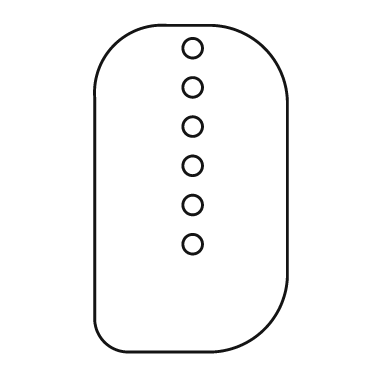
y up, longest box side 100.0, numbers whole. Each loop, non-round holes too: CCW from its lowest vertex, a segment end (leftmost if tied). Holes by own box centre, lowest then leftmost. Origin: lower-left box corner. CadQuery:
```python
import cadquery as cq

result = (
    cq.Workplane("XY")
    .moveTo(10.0, 0.0)
    .lineTo(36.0, 0.0)
    .threePointArc((52.0, 7.0), (59.0, 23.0))
    .lineTo(59.0, 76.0)
    .threePointArc((52.0, 93.0), (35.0, 100.0))
    .lineTo(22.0, 100.0)
    .threePointArc((6.0, 94.0), (0.0, 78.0))
    .lineTo(0.0, 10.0)
    .threePointArc((3.0, 3.0), (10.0, 0.0))
    .close()
    .moveTo(30.0, 33.0)
    .circle(3.0)
    .moveTo(30.0, 45.0)
    .circle(3.0)
    .moveTo(30.0, 57.0)
    .circle(3.0)
    .moveTo(30.0, 69.0)
    .circle(3.0)
    .moveTo(30.0, 81.0)
    .circle(3.0)
    .moveTo(30.0, 93.0)
    .circle(3.0)
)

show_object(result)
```